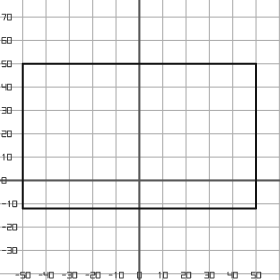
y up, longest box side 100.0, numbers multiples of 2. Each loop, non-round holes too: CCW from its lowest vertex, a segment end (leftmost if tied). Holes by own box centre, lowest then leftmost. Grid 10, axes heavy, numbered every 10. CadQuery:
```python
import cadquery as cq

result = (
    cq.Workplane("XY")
    .moveTo(-50.0, -12.0)
    .lineTo(50.0, -12.0)
    .lineTo(50.0, 50.0)
    .lineTo(-50.0, 50.0)
    .close()
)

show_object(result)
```